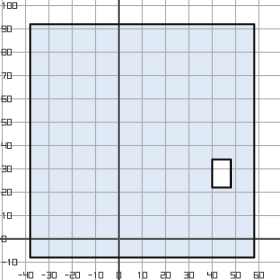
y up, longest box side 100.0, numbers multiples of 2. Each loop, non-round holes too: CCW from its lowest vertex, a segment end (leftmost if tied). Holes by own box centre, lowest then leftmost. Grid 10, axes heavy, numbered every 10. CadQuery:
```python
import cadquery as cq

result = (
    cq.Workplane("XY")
    .moveTo(-38.0, -8.0)
    .lineTo(58.0, -8.0)
    .lineTo(58.0, 92.0)
    .lineTo(-38.0, 92.0)
    .close()
    .moveTo(40.0, 22.0)
    .lineTo(48.0, 22.0)
    .lineTo(48.0, 34.0)
    .lineTo(40.0, 34.0)
    .close()
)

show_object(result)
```